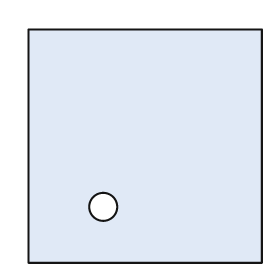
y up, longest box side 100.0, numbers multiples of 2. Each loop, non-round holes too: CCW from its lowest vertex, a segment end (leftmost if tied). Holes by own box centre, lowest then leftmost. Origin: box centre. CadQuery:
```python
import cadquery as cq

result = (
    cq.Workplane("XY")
    .moveTo(-50.0, -50.0)
    .lineTo(50.0, -50.0)
    .lineTo(50.0, 50.0)
    .lineTo(-50.0, 50.0)
    .close()
    .moveTo(-18.0, -26.0)
    .circle(6.0)
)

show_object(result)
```